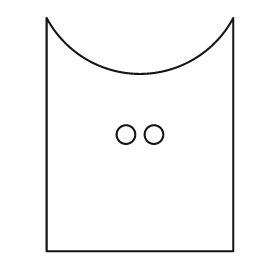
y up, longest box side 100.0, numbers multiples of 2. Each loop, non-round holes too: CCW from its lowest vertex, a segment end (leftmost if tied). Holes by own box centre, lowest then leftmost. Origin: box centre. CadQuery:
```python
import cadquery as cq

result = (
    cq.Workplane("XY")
    .moveTo(-40.0, -50.0)
    .lineTo(40.0, -50.0)
    .lineTo(40.0, 50.0)
    .threePointArc((0.0, 26.0), (-40.0, 50.0))
    .close()
    .moveTo(-6.0, 0.0)
    .circle(4.0)
    .moveTo(6.0, 0.0)
    .circle(4.0)
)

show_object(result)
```